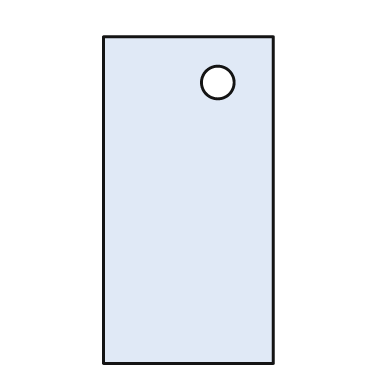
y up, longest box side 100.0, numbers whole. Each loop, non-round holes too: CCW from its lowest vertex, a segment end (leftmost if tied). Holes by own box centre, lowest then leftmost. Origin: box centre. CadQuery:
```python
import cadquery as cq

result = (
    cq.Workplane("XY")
    .moveTo(-26.0, -50.0)
    .lineTo(26.0, -50.0)
    .lineTo(26.0, 50.0)
    .lineTo(-26.0, 50.0)
    .close()
    .moveTo(9.0, 36.0)
    .circle(5.0)
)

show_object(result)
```